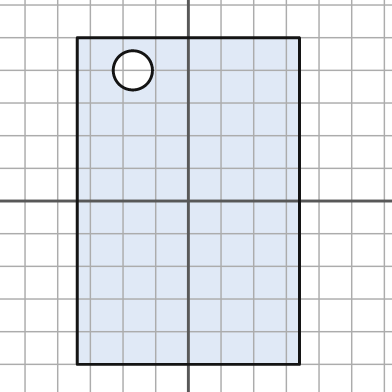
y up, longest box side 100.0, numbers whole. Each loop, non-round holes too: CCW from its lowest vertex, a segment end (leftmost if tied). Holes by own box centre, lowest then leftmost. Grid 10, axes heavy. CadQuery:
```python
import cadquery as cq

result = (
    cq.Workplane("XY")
    .moveTo(-34.0, -50.0)
    .lineTo(34.0, -50.0)
    .lineTo(34.0, 50.0)
    .lineTo(-34.0, 50.0)
    .close()
    .moveTo(-17.0, 40.0)
    .circle(6.0)
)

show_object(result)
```